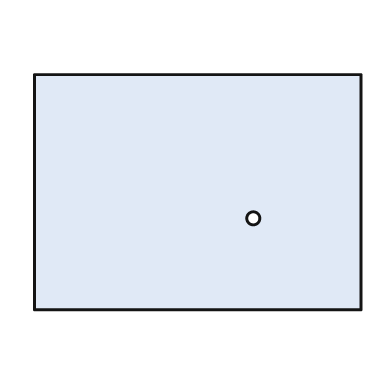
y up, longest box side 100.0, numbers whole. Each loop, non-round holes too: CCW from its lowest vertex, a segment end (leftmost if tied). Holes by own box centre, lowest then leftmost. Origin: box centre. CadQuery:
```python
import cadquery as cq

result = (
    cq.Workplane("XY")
    .moveTo(-50.0, -36.0)
    .lineTo(50.0, -36.0)
    .lineTo(50.0, 36.0)
    .lineTo(-50.0, 36.0)
    .close()
    .moveTo(17.0, -8.0)
    .circle(2.0)
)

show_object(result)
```